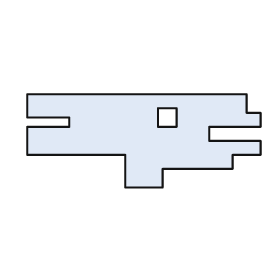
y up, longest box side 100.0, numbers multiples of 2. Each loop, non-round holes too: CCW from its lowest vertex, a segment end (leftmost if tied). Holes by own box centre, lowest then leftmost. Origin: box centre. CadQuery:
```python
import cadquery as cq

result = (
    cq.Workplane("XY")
    .moveTo(-8.0, -20.0)
    .lineTo(8.0, -20.0)
    .lineTo(8.0, -12.0)
    .lineTo(38.0, -12.0)
    .lineTo(38.0, -6.0)
    .lineTo(50.0, -6.0)
    .lineTo(50.0, 0.0)
    .lineTo(28.0, 0.0)
    .lineTo(28.0, 6.0)
    .lineTo(50.0, 6.0)
    .lineTo(50.0, 12.0)
    .lineTo(44.0, 12.0)
    .lineTo(44.0, 20.0)
    .lineTo(-50.0, 20.0)
    .lineTo(-50.0, 10.0)
    .lineTo(-32.0, 10.0)
    .lineTo(-32.0, 6.0)
    .lineTo(-50.0, 6.0)
    .lineTo(-50.0, -6.0)
    .lineTo(-8.0, -6.0)
    .close()
    .moveTo(6.0, 6.0)
    .lineTo(14.0, 6.0)
    .lineTo(14.0, 14.0)
    .lineTo(6.0, 14.0)
    .close()
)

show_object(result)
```